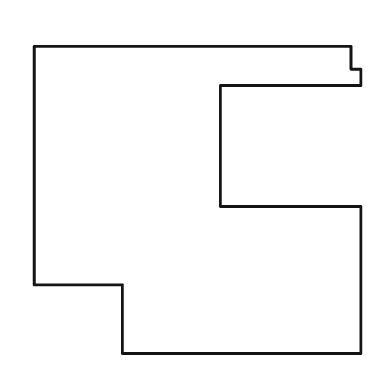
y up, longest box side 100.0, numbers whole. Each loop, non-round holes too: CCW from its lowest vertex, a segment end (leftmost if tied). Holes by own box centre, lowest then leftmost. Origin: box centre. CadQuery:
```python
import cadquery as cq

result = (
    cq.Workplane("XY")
    .moveTo(-23.0, -47.0)
    .lineTo(50.0, -47.0)
    .lineTo(50.0, -2.0)
    .lineTo(7.0, -2.0)
    .lineTo(7.0, 35.0)
    .lineTo(50.0, 35.0)
    .lineTo(50.0, 40.0)
    .lineTo(47.0, 40.0)
    .lineTo(47.0, 47.0)
    .lineTo(-50.0, 47.0)
    .lineTo(-50.0, -26.0)
    .lineTo(-23.0, -26.0)
    .close()
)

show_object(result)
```